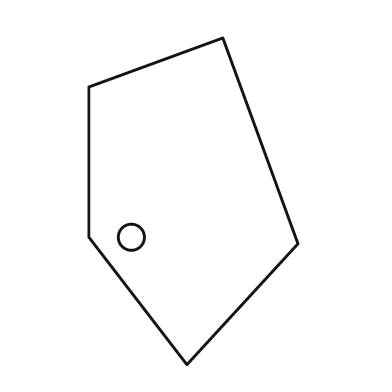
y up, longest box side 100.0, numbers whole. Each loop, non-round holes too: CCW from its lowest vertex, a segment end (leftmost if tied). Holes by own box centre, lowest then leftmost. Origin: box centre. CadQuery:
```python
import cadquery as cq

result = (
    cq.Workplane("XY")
    .moveTo(-2.0, -50.0)
    .lineTo(32.0, -13.0)
    .lineTo(9.0, 50.0)
    .lineTo(-32.0, 35.0)
    .lineTo(-32.0, -11.0)
    .close()
    .moveTo(-19.0, -11.0)
    .circle(4.0)
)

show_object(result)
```